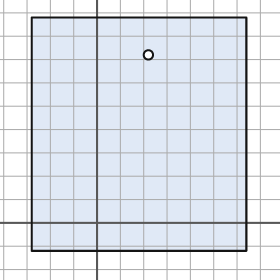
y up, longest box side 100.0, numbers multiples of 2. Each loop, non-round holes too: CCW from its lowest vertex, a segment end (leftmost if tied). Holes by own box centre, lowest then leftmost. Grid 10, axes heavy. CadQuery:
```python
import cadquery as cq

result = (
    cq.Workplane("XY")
    .moveTo(-28.0, -12.0)
    .lineTo(64.0, -12.0)
    .lineTo(64.0, 88.0)
    .lineTo(-28.0, 88.0)
    .close()
    .moveTo(22.0, 72.0)
    .circle(2.0)
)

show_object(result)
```